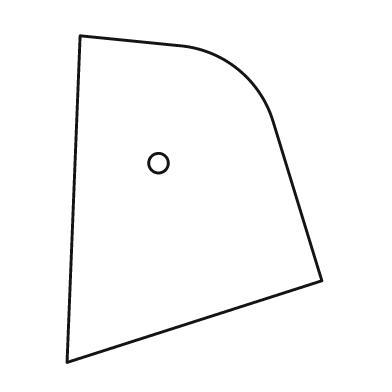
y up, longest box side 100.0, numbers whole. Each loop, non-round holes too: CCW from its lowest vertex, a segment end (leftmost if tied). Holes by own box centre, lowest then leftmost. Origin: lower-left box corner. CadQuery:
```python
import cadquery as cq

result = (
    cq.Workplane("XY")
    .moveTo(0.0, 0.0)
    .lineTo(78.0, 25.0)
    .lineTo(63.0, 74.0)
    .threePointArc((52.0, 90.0), (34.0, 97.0))
    .lineTo(4.0, 100.0)
    .close()
    .moveTo(28.0, 61.0)
    .circle(3.0)
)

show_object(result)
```